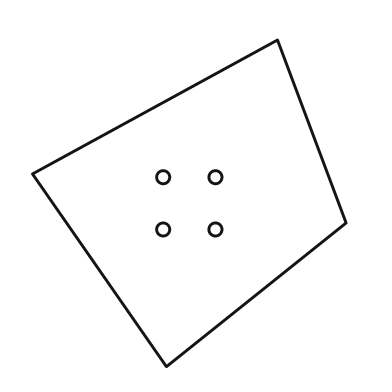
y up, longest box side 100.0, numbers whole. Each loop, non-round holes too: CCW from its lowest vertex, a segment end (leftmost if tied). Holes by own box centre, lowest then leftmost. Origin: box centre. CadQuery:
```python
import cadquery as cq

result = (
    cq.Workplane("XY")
    .moveTo(-7.0, -50.0)
    .lineTo(48.0, -6.0)
    .lineTo(27.0, 50.0)
    .lineTo(-48.0, 9.0)
    .close()
    .moveTo(-8.0, -8.0)
    .circle(2.0)
    .moveTo(8.0, -8.0)
    .circle(2.0)
    .moveTo(-8.0, 8.0)
    .circle(2.0)
    .moveTo(8.0, 8.0)
    .circle(2.0)
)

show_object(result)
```